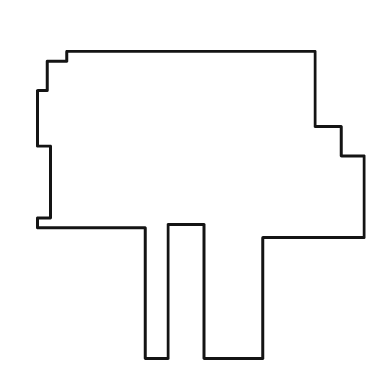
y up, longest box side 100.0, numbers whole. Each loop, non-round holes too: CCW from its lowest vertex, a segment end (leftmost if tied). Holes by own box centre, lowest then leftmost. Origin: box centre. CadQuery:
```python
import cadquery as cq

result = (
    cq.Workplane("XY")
    .moveTo(-17.0, -47.0)
    .lineTo(-10.0, -47.0)
    .lineTo(-10.0, -6.0)
    .lineTo(1.0, -6.0)
    .lineTo(1.0, -47.0)
    .lineTo(19.0, -47.0)
    .lineTo(19.0, -10.0)
    .lineTo(50.0, -10.0)
    .lineTo(50.0, 15.0)
    .lineTo(43.0, 15.0)
    .lineTo(43.0, 24.0)
    .lineTo(35.0, 24.0)
    .lineTo(35.0, 47.0)
    .lineTo(-41.0, 47.0)
    .lineTo(-41.0, 44.0)
    .lineTo(-47.0, 44.0)
    .lineTo(-47.0, 35.0)
    .lineTo(-50.0, 35.0)
    .lineTo(-50.0, 18.0)
    .lineTo(-46.0, 18.0)
    .lineTo(-46.0, -4.0)
    .lineTo(-50.0, -4.0)
    .lineTo(-50.0, -7.0)
    .lineTo(-17.0, -7.0)
    .close()
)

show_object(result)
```